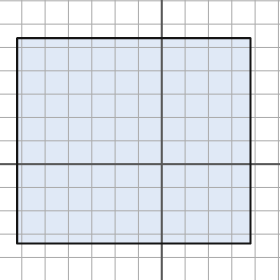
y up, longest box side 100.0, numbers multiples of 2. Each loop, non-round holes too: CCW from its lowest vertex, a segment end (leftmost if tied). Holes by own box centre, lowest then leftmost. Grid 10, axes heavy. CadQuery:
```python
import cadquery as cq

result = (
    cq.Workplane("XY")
    .moveTo(-62.0, -34.0)
    .lineTo(38.0, -34.0)
    .lineTo(38.0, 54.0)
    .lineTo(-62.0, 54.0)
    .close()
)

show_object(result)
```